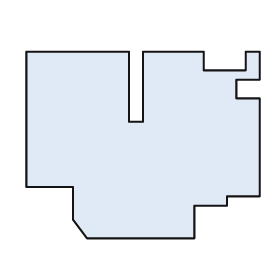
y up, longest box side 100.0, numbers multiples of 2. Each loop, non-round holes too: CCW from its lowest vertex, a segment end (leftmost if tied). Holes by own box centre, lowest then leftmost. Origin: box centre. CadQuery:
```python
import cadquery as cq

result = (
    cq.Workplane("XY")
    .moveTo(-24.0, -40.0)
    .lineTo(22.0, -40.0)
    .lineTo(22.0, -26.0)
    .lineTo(36.0, -26.0)
    .lineTo(36.0, -22.0)
    .lineTo(50.0, -22.0)
    .lineTo(50.0, 20.0)
    .lineTo(40.0, 20.0)
    .lineTo(40.0, 28.0)
    .lineTo(50.0, 28.0)
    .lineTo(50.0, 40.0)
    .lineTo(44.0, 40.0)
    .lineTo(44.0, 32.0)
    .lineTo(26.0, 32.0)
    .lineTo(26.0, 40.0)
    .lineTo(0.0, 40.0)
    .lineTo(0.0, 10.0)
    .lineTo(-6.0, 10.0)
    .lineTo(-6.0, 40.0)
    .lineTo(-50.0, 40.0)
    .lineTo(-50.0, -18.0)
    .lineTo(-30.0, -18.0)
    .lineTo(-30.0, -32.0)
    .close()
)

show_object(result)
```